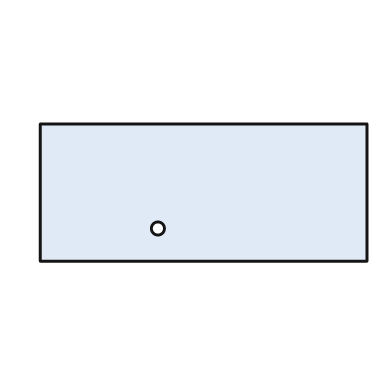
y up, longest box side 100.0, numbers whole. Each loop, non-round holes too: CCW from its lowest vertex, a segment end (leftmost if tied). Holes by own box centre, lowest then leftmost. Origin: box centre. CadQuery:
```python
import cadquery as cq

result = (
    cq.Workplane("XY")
    .moveTo(-50.0, -21.0)
    .lineTo(50.0, -21.0)
    .lineTo(50.0, 21.0)
    .lineTo(-50.0, 21.0)
    .close()
    .moveTo(-14.0, -11.0)
    .circle(2.0)
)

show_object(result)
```